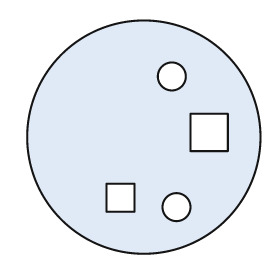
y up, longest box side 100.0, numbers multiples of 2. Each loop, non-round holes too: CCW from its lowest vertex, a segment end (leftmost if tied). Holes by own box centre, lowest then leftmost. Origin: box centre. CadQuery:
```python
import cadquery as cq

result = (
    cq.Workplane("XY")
    .moveTo(0.0, 0.0)
    .circle(50.0)
    .moveTo(14.0, -30.0)
    .circle(6.0)
    .moveTo(-16.0, -32.0)
    .lineTo(-4.0, -32.0)
    .lineTo(-4.0, -20.0)
    .lineTo(-16.0, -20.0)
    .close()
    .moveTo(20.0, -6.0)
    .lineTo(36.0, -6.0)
    .lineTo(36.0, 10.0)
    .lineTo(20.0, 10.0)
    .close()
    .moveTo(12.0, 26.0)
    .circle(6.0)
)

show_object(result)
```